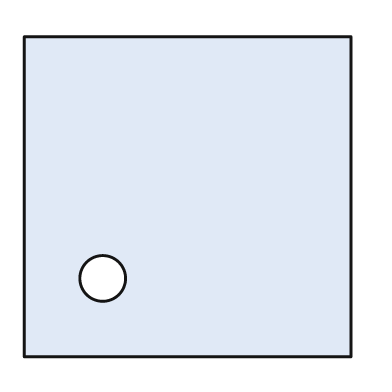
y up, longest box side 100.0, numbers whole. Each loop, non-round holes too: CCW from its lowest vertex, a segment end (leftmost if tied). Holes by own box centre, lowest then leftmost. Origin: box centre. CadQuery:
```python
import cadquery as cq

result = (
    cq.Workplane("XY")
    .moveTo(-50.0, -49.0)
    .lineTo(50.0, -49.0)
    .lineTo(50.0, 49.0)
    .lineTo(-50.0, 49.0)
    .close()
    .moveTo(-26.0, -25.0)
    .circle(7.0)
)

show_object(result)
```